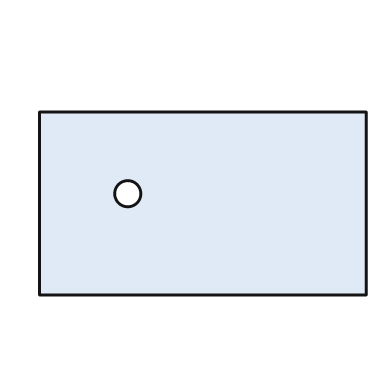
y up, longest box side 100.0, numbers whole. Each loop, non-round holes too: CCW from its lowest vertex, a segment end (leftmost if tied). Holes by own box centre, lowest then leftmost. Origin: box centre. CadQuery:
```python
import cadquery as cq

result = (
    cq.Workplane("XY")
    .moveTo(-50.0, -28.0)
    .lineTo(50.0, -28.0)
    .lineTo(50.0, 28.0)
    .lineTo(-50.0, 28.0)
    .close()
    .moveTo(-23.0, 3.0)
    .circle(4.0)
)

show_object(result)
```